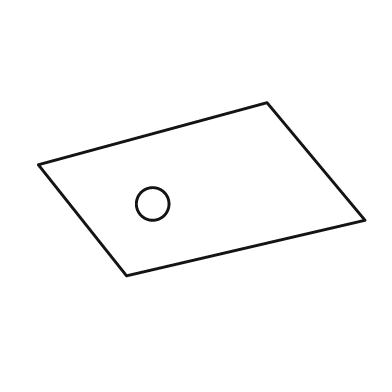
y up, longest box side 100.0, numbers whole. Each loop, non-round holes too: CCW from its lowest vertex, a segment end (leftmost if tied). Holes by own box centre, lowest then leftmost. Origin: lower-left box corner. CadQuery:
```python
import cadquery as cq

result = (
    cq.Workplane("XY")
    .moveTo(27.0, 0.0)
    .lineTo(100.0, 17.0)
    .lineTo(70.0, 53.0)
    .lineTo(0.0, 34.0)
    .close()
    .moveTo(35.0, 22.0)
    .circle(5.0)
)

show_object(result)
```